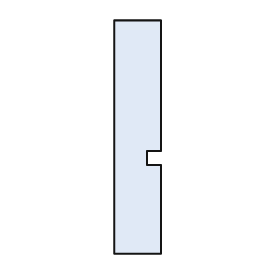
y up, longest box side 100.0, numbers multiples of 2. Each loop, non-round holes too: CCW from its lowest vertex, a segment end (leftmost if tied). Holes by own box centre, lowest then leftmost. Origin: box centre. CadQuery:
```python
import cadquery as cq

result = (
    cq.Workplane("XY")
    .moveTo(-10.0, -50.0)
    .lineTo(10.0, -50.0)
    .lineTo(10.0, -12.0)
    .lineTo(4.0, -12.0)
    .lineTo(4.0, -6.0)
    .lineTo(10.0, -6.0)
    .lineTo(10.0, 50.0)
    .lineTo(-10.0, 50.0)
    .close()
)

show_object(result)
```